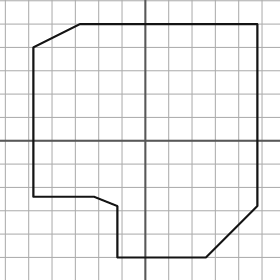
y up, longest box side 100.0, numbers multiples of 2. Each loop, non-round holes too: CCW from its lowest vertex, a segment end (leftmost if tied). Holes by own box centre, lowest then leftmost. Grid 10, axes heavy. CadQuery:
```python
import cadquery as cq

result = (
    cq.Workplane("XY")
    .moveTo(-12.0, -50.0)
    .lineTo(26.0, -50.0)
    .lineTo(48.0, -28.0)
    .lineTo(48.0, 50.0)
    .lineTo(-28.0, 50.0)
    .lineTo(-48.0, 40.0)
    .lineTo(-48.0, -24.0)
    .lineTo(-22.0, -24.0)
    .lineTo(-12.0, -28.0)
    .close()
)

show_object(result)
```